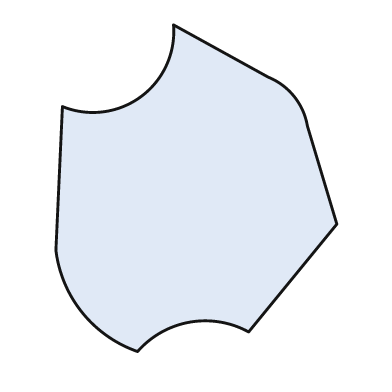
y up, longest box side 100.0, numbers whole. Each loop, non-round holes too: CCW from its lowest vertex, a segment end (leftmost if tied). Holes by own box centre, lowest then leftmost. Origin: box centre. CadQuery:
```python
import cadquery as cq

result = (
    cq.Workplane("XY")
    .moveTo(-18.0, -50.0)
    .threePointArc((-2.0, -41.0), (16.0, -44.0))
    .lineTo(43.0, -11.0)
    .lineTo(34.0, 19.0)
    .threePointArc((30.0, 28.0), (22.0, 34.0))
    .lineTo(-7.0, 50.0)
    .threePointArc((-17.0, 28.0), (-41.0, 25.0))
    .lineTo(-43.0, -19.0)
    .threePointArc((-35.0, -38.0), (-18.0, -50.0))
    .close()
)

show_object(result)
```